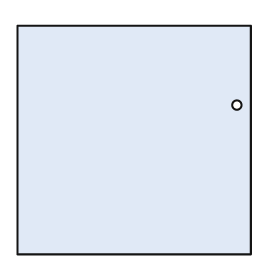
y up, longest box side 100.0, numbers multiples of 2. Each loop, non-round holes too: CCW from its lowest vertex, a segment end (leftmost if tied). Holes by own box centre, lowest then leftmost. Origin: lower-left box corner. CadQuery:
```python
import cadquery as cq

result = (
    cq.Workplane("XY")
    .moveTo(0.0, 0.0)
    .lineTo(100.0, 0.0)
    .lineTo(100.0, 98.0)
    .lineTo(0.0, 98.0)
    .close()
    .moveTo(94.0, 64.0)
    .circle(2.0)
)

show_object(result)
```